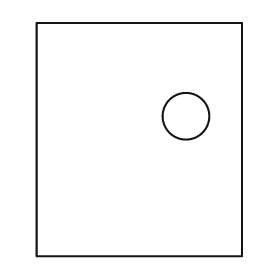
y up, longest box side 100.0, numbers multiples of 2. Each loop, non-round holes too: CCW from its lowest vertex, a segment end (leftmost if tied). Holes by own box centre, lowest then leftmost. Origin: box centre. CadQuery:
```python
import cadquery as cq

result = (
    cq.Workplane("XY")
    .moveTo(-44.0, -50.0)
    .lineTo(44.0, -50.0)
    .lineTo(44.0, 50.0)
    .lineTo(-44.0, 50.0)
    .close()
    .moveTo(20.0, 10.0)
    .circle(10.0)
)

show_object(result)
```